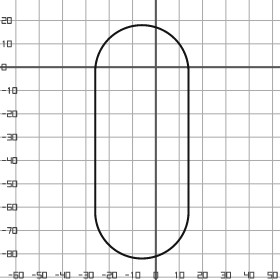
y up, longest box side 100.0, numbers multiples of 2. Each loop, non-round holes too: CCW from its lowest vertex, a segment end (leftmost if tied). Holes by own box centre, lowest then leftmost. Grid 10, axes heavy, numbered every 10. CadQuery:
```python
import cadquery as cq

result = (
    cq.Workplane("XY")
    .moveTo(-26.0, -62.0)
    .threePointArc((-6.0, -82.0), (14.0, -62.0))
    .lineTo(14.0, -2.0)
    .threePointArc((-6.0, 18.0), (-26.0, -2.0))
    .close()
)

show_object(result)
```